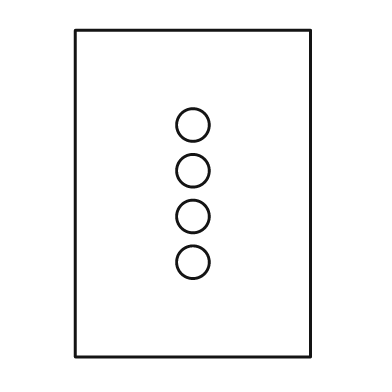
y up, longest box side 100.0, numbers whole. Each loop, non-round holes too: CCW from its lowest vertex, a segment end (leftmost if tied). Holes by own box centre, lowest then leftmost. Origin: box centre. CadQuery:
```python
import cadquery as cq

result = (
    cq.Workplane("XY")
    .moveTo(-36.0, -50.0)
    .lineTo(36.0, -50.0)
    .lineTo(36.0, 50.0)
    .lineTo(-36.0, 50.0)
    .close()
    .moveTo(0.0, -21.0)
    .circle(5.0)
    .moveTo(0.0, -7.0)
    .circle(5.0)
    .moveTo(0.0, 7.0)
    .circle(5.0)
    .moveTo(0.0, 21.0)
    .circle(5.0)
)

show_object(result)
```